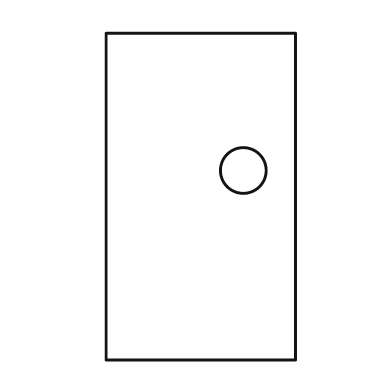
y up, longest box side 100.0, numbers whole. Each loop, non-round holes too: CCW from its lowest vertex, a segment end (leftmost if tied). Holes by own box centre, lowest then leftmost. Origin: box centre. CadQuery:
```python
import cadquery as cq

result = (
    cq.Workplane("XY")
    .moveTo(-29.0, -50.0)
    .lineTo(29.0, -50.0)
    .lineTo(29.0, 50.0)
    .lineTo(-29.0, 50.0)
    .close()
    .moveTo(13.0, 8.0)
    .circle(7.0)
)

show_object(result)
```